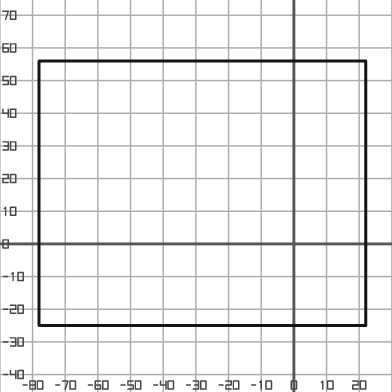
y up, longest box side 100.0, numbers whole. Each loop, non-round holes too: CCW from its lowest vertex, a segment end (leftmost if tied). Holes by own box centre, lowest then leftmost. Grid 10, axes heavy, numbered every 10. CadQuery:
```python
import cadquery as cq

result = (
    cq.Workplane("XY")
    .moveTo(-78.0, -25.0)
    .lineTo(22.0, -25.0)
    .lineTo(22.0, 56.0)
    .lineTo(-78.0, 56.0)
    .close()
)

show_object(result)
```